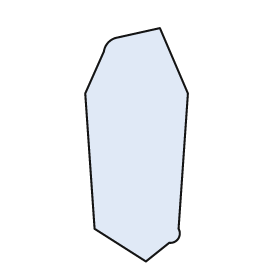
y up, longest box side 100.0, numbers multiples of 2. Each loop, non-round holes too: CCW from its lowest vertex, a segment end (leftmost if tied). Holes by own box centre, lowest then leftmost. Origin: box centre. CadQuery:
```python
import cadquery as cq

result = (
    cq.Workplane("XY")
    .moveTo(4.0, -50.0)
    .lineTo(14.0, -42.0)
    .threePointArc((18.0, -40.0), (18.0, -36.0))
    .lineTo(22.0, 22.0)
    .lineTo(10.0, 50.0)
    .lineTo(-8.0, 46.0)
    .threePointArc((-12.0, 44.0), (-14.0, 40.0))
    .lineTo(-22.0, 22.0)
    .lineTo(-18.0, -36.0)
    .close()
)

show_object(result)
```